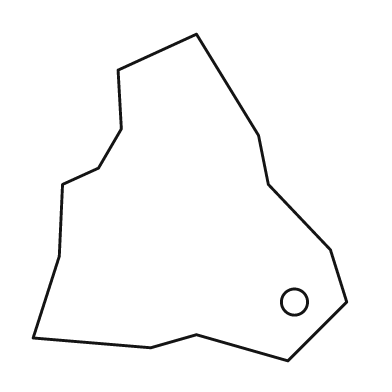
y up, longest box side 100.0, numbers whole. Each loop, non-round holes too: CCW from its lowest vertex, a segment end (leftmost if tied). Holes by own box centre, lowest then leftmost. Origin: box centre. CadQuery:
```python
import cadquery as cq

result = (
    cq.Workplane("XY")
    .moveTo(30.0, -50.0)
    .lineTo(48.0, -32.0)
    .lineTo(43.0, -16.0)
    .lineTo(24.0, 4.0)
    .lineTo(21.0, 19.0)
    .lineTo(2.0, 50.0)
    .lineTo(-22.0, 39.0)
    .lineTo(-21.0, 21.0)
    .lineTo(-28.0, 9.0)
    .lineTo(-39.0, 4.0)
    .lineTo(-40.0, -18.0)
    .lineTo(-48.0, -43.0)
    .lineTo(-12.0, -46.0)
    .lineTo(2.0, -42.0)
    .close()
    .moveTo(32.0, -32.0)
    .circle(4.0)
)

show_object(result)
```